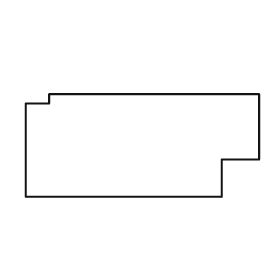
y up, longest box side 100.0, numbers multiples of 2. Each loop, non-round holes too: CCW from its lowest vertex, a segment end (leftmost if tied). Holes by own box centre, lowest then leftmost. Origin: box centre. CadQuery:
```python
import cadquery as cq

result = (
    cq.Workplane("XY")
    .moveTo(-50.0, -22.0)
    .lineTo(34.0, -22.0)
    .lineTo(34.0, -6.0)
    .lineTo(50.0, -6.0)
    .lineTo(50.0, 22.0)
    .lineTo(-40.0, 22.0)
    .lineTo(-40.0, 18.0)
    .lineTo(-50.0, 18.0)
    .close()
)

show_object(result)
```